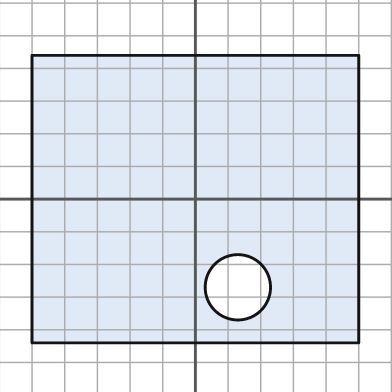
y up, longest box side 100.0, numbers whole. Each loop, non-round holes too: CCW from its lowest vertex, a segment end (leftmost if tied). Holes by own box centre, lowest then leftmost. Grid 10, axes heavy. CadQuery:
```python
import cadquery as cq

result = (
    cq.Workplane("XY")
    .moveTo(-50.0, -44.0)
    .lineTo(50.0, -44.0)
    .lineTo(50.0, 44.0)
    .lineTo(-50.0, 44.0)
    .close()
    .moveTo(13.0, -27.0)
    .circle(10.0)
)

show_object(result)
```